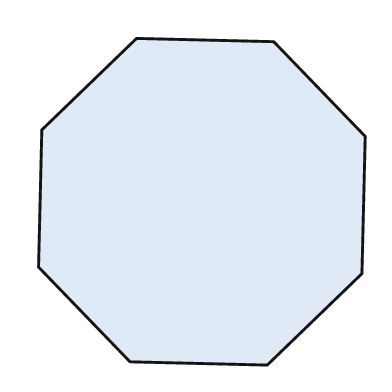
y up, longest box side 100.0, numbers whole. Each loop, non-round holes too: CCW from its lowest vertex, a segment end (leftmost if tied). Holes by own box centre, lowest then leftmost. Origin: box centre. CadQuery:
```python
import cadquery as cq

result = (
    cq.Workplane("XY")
    .moveTo(20.0, -50.0)
    .lineTo(49.0, -22.0)
    .lineTo(50.0, 20.0)
    .lineTo(22.0, 49.0)
    .lineTo(-20.0, 50.0)
    .lineTo(-49.0, 22.0)
    .lineTo(-50.0, -20.0)
    .lineTo(-22.0, -49.0)
    .close()
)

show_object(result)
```